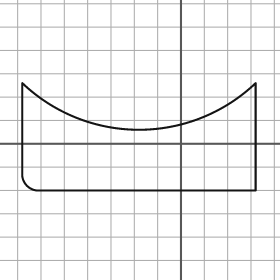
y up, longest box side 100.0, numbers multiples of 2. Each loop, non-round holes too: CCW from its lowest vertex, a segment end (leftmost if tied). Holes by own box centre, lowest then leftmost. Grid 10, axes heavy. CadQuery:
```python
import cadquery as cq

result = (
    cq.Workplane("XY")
    .moveTo(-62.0, -20.0)
    .lineTo(32.0, -20.0)
    .lineTo(32.0, 26.0)
    .threePointArc((-18.0, 6.0), (-68.0, 26.0))
    .lineTo(-68.0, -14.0)
    .threePointArc((-66.0, -18.0), (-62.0, -20.0))
    .close()
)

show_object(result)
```